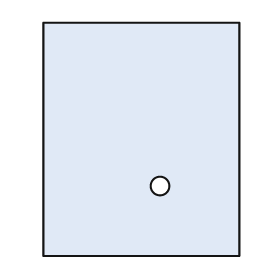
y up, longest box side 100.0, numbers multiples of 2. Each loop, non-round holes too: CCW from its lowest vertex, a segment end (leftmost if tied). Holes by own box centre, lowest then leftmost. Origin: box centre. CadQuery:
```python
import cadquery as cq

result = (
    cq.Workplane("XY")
    .moveTo(-42.0, -50.0)
    .lineTo(42.0, -50.0)
    .lineTo(42.0, 50.0)
    .lineTo(-42.0, 50.0)
    .close()
    .moveTo(8.0, -20.0)
    .circle(4.0)
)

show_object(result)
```